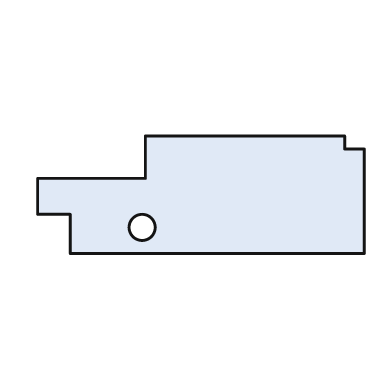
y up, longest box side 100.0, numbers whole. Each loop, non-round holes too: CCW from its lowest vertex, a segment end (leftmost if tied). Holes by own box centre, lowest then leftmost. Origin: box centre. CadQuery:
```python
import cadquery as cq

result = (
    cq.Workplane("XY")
    .moveTo(-40.0, -18.0)
    .lineTo(50.0, -18.0)
    .lineTo(50.0, 14.0)
    .lineTo(44.0, 14.0)
    .lineTo(44.0, 18.0)
    .lineTo(-17.0, 18.0)
    .lineTo(-17.0, 5.0)
    .lineTo(-50.0, 5.0)
    .lineTo(-50.0, -6.0)
    .lineTo(-40.0, -6.0)
    .close()
    .moveTo(-18.0, -10.0)
    .circle(4.0)
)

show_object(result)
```